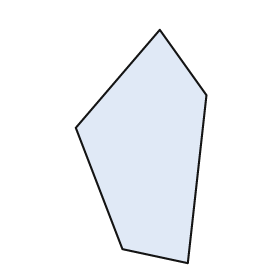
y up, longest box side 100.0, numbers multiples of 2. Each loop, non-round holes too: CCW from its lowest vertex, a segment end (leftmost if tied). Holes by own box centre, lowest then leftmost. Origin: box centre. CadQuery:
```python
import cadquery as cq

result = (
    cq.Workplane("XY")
    .moveTo(20.0, -50.0)
    .lineTo(28.0, 22.0)
    .lineTo(8.0, 50.0)
    .lineTo(-28.0, 8.0)
    .lineTo(-8.0, -44.0)
    .close()
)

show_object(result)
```